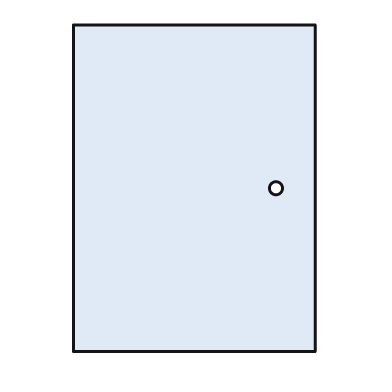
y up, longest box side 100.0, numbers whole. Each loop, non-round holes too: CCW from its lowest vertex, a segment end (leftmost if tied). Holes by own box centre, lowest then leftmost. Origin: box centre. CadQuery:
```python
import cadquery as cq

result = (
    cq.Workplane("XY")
    .moveTo(-37.0, -50.0)
    .lineTo(37.0, -50.0)
    .lineTo(37.0, 50.0)
    .lineTo(-37.0, 50.0)
    .close()
    .moveTo(25.0, 0.0)
    .circle(2.0)
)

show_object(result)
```